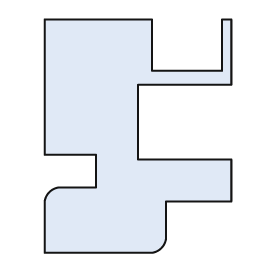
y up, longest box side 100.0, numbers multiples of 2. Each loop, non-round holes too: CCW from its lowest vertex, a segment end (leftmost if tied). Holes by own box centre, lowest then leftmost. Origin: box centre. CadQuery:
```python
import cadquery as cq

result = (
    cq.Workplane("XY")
    .moveTo(-40.0, -50.0)
    .lineTo(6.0, -50.0)
    .threePointArc((10.0, -48.0), (12.0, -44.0))
    .lineTo(12.0, -28.0)
    .lineTo(40.0, -28.0)
    .lineTo(40.0, -10.0)
    .lineTo(0.0, -10.0)
    .lineTo(0.0, 22.0)
    .lineTo(40.0, 22.0)
    .lineTo(40.0, 50.0)
    .lineTo(36.0, 50.0)
    .lineTo(36.0, 28.0)
    .lineTo(6.0, 28.0)
    .lineTo(6.0, 50.0)
    .lineTo(-40.0, 50.0)
    .lineTo(-40.0, -8.0)
    .lineTo(-18.0, -8.0)
    .lineTo(-18.0, -22.0)
    .lineTo(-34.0, -22.0)
    .threePointArc((-38.0, -24.0), (-40.0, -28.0))
    .close()
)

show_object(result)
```